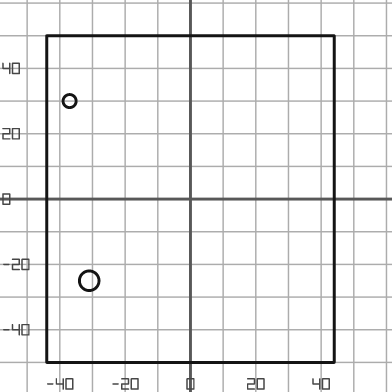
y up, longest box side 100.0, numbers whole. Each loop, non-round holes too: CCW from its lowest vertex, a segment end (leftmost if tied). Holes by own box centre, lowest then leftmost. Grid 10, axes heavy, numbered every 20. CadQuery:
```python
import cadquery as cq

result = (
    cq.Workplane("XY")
    .moveTo(-44.0, -50.0)
    .lineTo(44.0, -50.0)
    .lineTo(44.0, 50.0)
    .lineTo(-44.0, 50.0)
    .close()
    .moveTo(-31.0, -25.0)
    .circle(3.0)
    .moveTo(-37.0, 30.0)
    .circle(2.0)
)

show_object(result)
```